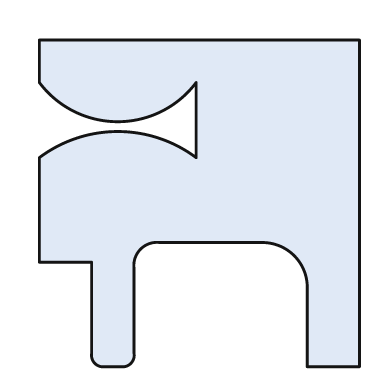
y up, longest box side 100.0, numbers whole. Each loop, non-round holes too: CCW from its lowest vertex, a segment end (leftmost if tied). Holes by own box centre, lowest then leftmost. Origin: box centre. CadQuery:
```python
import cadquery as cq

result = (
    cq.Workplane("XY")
    .moveTo(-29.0, -50.0)
    .lineTo(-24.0, -50.0)
    .threePointArc((-21.0, -49.0), (-20.0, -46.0))
    .lineTo(-20.0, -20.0)
    .threePointArc((-18.0, -14.0), (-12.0, -12.0))
    .lineTo(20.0, -12.0)
    .threePointArc((29.0, -16.0), (33.0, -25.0))
    .lineTo(33.0, -50.0)
    .lineTo(49.0, -50.0)
    .lineTo(49.0, 50.0)
    .lineTo(-49.0, 50.0)
    .lineTo(-49.0, 37.0)
    .threePointArc((-25.0, 25.0), (-1.0, 37.0))
    .lineTo(-1.0, 14.0)
    .threePointArc((-25.0, 22.0), (-49.0, 14.0))
    .lineTo(-49.0, -18.0)
    .lineTo(-33.0, -18.0)
    .lineTo(-33.0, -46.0)
    .threePointArc((-32.0, -49.0), (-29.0, -50.0))
    .close()
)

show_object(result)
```